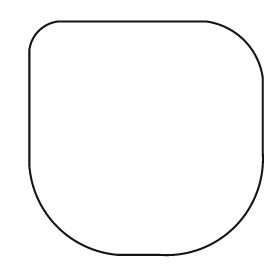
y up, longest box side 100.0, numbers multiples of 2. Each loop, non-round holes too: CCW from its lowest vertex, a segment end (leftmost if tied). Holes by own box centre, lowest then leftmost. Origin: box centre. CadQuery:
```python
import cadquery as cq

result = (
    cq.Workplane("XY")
    .moveTo(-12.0, -50.0)
    .lineTo(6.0, -50.0)
    .threePointArc((38.0, -38.0), (50.0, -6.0))
    .lineTo(50.0, 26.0)
    .threePointArc((42.0, 42.0), (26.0, 50.0))
    .lineTo(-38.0, 50.0)
    .threePointArc((-46.0, 46.0), (-50.0, 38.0))
    .lineTo(-50.0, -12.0)
    .threePointArc((-38.0, -38.0), (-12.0, -50.0))
    .close()
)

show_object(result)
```